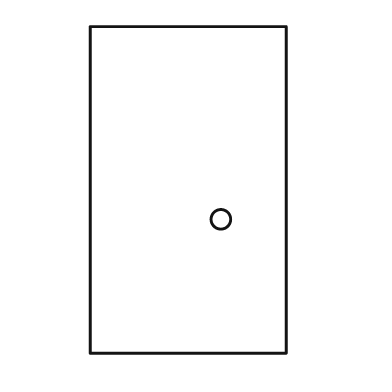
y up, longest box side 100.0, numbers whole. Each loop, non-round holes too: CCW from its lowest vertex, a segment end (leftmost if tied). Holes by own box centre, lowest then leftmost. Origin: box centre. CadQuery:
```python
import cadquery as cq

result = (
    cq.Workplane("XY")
    .moveTo(-30.0, -50.0)
    .lineTo(30.0, -50.0)
    .lineTo(30.0, 50.0)
    .lineTo(-30.0, 50.0)
    .close()
    .moveTo(10.0, -9.0)
    .circle(3.0)
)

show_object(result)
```